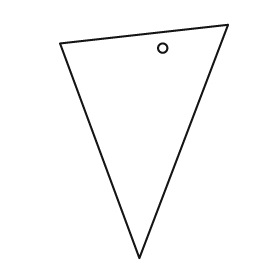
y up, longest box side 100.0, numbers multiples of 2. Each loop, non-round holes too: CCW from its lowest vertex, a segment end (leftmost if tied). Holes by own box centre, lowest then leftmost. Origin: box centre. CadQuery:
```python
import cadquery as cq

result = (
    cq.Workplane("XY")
    .moveTo(-2.0, -50.0)
    .lineTo(36.0, 50.0)
    .lineTo(-36.0, 42.0)
    .close()
    .moveTo(8.0, 40.0)
    .circle(2.0)
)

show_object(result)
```